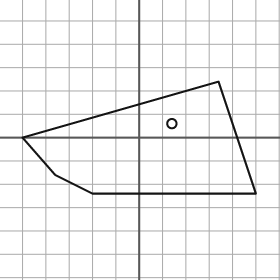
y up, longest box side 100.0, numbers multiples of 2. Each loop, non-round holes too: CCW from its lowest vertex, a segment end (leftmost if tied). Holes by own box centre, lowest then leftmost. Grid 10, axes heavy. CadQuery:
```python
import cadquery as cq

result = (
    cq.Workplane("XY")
    .moveTo(-20.0, -24.0)
    .lineTo(50.0, -24.0)
    .lineTo(34.0, 24.0)
    .lineTo(-50.0, 0.0)
    .lineTo(-36.0, -16.0)
    .close()
    .moveTo(14.0, 6.0)
    .circle(2.0)
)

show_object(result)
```